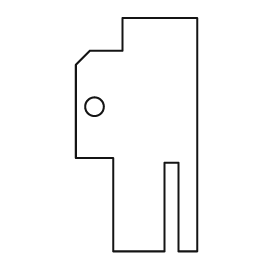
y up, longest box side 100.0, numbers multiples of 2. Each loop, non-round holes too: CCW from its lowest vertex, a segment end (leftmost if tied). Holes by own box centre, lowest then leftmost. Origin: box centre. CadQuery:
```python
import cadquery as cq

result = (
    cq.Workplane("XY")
    .moveTo(-10.0, -50.0)
    .lineTo(12.0, -50.0)
    .lineTo(12.0, -12.0)
    .lineTo(18.0, -12.0)
    .lineTo(18.0, -50.0)
    .lineTo(26.0, -50.0)
    .lineTo(26.0, 50.0)
    .lineTo(-6.0, 50.0)
    .lineTo(-6.0, 36.0)
    .lineTo(-20.0, 36.0)
    .lineTo(-26.0, 30.0)
    .lineTo(-26.0, -10.0)
    .lineTo(-10.0, -10.0)
    .close()
    .moveTo(-18.0, 12.0)
    .circle(4.0)
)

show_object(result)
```